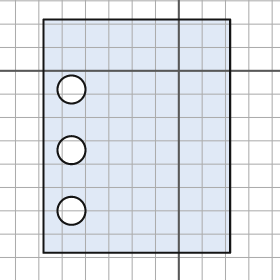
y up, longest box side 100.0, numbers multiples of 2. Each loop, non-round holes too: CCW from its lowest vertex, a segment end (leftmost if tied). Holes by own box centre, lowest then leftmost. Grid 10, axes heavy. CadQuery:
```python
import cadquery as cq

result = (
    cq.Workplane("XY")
    .moveTo(-58.0, -78.0)
    .lineTo(22.0, -78.0)
    .lineTo(22.0, 22.0)
    .lineTo(-58.0, 22.0)
    .close()
    .moveTo(-46.0, -60.0)
    .circle(6.0)
    .moveTo(-46.0, -34.0)
    .circle(6.0)
    .moveTo(-46.0, -8.0)
    .circle(6.0)
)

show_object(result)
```